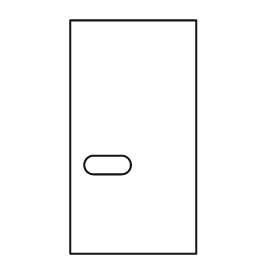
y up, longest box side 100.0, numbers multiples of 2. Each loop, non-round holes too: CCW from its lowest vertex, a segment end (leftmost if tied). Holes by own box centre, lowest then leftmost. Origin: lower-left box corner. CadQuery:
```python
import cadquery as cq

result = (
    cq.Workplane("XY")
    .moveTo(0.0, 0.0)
    .lineTo(54.0, 0.0)
    .lineTo(54.0, 100.0)
    .lineTo(0.0, 100.0)
    .close()
    .moveTo(10.0, 34.0)
    .lineTo(22.0, 34.0)
    .threePointArc((26.0, 38.0), (22.0, 42.0))
    .lineTo(10.0, 42.0)
    .threePointArc((6.0, 38.0), (10.0, 34.0))
    .close()
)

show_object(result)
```